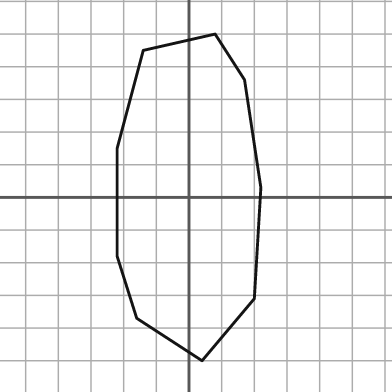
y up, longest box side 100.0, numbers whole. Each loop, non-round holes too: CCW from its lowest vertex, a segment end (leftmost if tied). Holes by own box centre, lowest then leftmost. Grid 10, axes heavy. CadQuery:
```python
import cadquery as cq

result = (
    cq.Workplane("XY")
    .moveTo(4.0, -50.0)
    .lineTo(20.0, -31.0)
    .lineTo(22.0, 3.0)
    .lineTo(17.0, 36.0)
    .lineTo(8.0, 50.0)
    .lineTo(-14.0, 45.0)
    .lineTo(-22.0, 15.0)
    .lineTo(-22.0, -18.0)
    .lineTo(-16.0, -37.0)
    .close()
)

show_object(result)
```